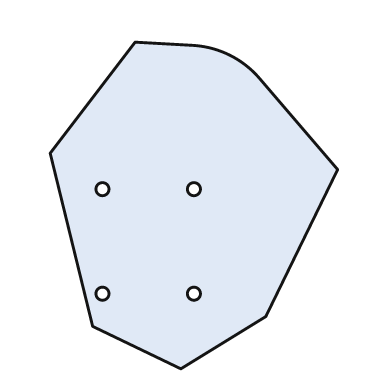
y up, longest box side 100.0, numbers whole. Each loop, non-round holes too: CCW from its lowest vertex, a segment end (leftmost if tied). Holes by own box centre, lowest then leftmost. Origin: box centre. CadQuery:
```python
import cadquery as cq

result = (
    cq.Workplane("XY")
    .moveTo(-4.0, -50.0)
    .lineTo(22.0, -34.0)
    .lineTo(44.0, 11.0)
    .lineTo(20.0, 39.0)
    .threePointArc((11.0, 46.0), (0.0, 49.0))
    .lineTo(-18.0, 50.0)
    .lineTo(-44.0, 16.0)
    .lineTo(-31.0, -37.0)
    .close()
    .moveTo(-28.0, -27.0)
    .circle(2.0)
    .moveTo(0.0, -27.0)
    .circle(2.0)
    .moveTo(-28.0, 5.0)
    .circle(2.0)
    .moveTo(0.0, 5.0)
    .circle(2.0)
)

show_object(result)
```